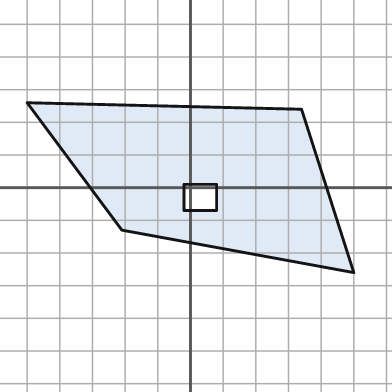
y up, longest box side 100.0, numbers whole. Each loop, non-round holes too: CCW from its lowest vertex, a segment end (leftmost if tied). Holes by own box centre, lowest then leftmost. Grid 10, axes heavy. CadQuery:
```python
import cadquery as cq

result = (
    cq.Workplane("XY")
    .moveTo(50.0, -26.0)
    .lineTo(34.0, 24.0)
    .lineTo(-50.0, 26.0)
    .lineTo(-21.0, -13.0)
    .close()
    .moveTo(-2.0, -7.0)
    .lineTo(8.0, -7.0)
    .lineTo(8.0, 1.0)
    .lineTo(-2.0, 1.0)
    .close()
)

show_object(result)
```